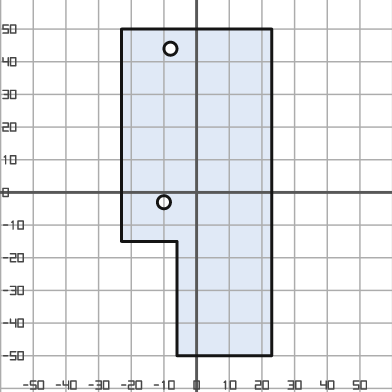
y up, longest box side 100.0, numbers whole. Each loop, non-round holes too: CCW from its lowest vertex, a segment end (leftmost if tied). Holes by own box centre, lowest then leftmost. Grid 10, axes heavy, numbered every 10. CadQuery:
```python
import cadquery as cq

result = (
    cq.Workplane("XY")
    .moveTo(-6.0, -50.0)
    .lineTo(23.0, -50.0)
    .lineTo(23.0, 50.0)
    .lineTo(-23.0, 50.0)
    .lineTo(-23.0, -15.0)
    .lineTo(-6.0, -15.0)
    .close()
    .moveTo(-10.0, -3.0)
    .circle(2.0)
    .moveTo(-8.0, 44.0)
    .circle(2.0)
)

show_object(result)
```